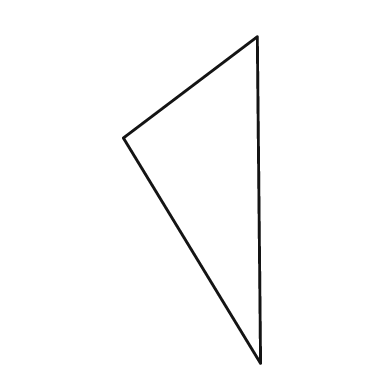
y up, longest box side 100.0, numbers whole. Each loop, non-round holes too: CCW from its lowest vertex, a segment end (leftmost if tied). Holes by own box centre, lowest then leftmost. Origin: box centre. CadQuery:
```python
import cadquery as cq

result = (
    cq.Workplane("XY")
    .moveTo(21.0, -50.0)
    .lineTo(20.0, 50.0)
    .lineTo(-21.0, 19.0)
    .close()
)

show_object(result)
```